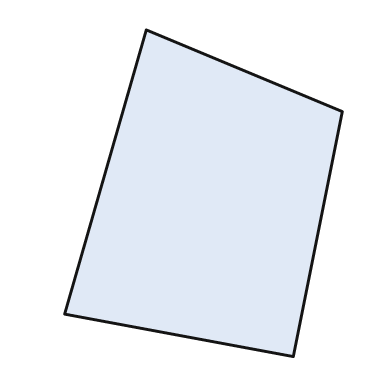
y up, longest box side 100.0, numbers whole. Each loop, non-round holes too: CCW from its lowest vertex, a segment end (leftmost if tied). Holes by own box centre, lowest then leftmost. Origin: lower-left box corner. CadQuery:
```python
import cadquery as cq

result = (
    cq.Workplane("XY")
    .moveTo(70.0, 0.0)
    .lineTo(85.0, 75.0)
    .lineTo(25.0, 100.0)
    .lineTo(0.0, 13.0)
    .close()
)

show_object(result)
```